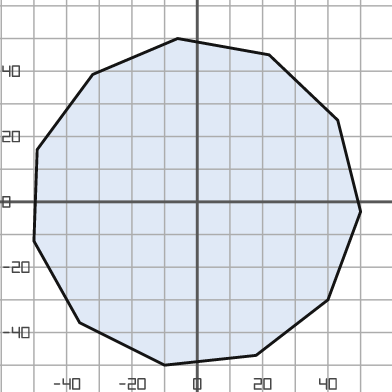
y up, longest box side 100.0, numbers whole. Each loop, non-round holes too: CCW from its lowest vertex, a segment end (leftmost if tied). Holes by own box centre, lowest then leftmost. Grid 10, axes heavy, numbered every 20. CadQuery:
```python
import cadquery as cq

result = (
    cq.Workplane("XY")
    .moveTo(-10.0, -50.0)
    .lineTo(18.0, -47.0)
    .lineTo(40.0, -30.0)
    .lineTo(50.0, -3.0)
    .lineTo(43.0, 25.0)
    .lineTo(22.0, 45.0)
    .lineTo(-6.0, 50.0)
    .lineTo(-32.0, 39.0)
    .lineTo(-49.0, 16.0)
    .lineTo(-50.0, -12.0)
    .lineTo(-36.0, -37.0)
    .close()
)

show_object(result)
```